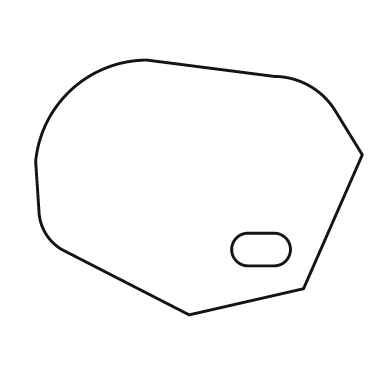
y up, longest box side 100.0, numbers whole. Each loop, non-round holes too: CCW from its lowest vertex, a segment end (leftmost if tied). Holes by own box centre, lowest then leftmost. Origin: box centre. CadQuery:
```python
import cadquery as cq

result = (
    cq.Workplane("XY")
    .moveTo(-3.0, -39.0)
    .lineTo(32.0, -31.0)
    .lineTo(50.0, 10.0)
    .lineTo(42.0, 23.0)
    .threePointArc((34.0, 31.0), (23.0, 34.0))
    .lineTo(-16.0, 39.0)
    .threePointArc((-39.0, 30.0), (-50.0, 8.0))
    .lineTo(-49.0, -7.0)
    .threePointArc((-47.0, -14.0), (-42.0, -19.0))
    .close()
    .moveTo(15.0, -24.0)
    .lineTo(23.0, -24.0)
    .threePointArc((28.0, -19.0), (23.0, -14.0))
    .lineTo(15.0, -14.0)
    .threePointArc((10.0, -19.0), (15.0, -24.0))
    .close()
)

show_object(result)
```